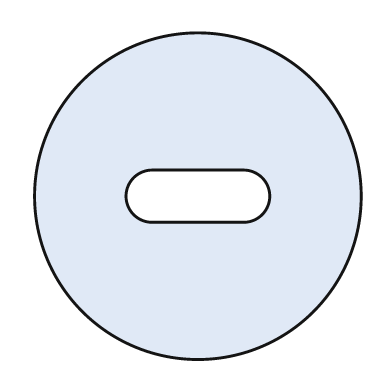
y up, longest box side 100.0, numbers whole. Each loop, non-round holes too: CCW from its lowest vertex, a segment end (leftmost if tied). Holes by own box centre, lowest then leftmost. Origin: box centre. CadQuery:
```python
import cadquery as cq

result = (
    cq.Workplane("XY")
    .moveTo(0.0, 0.0)
    .circle(50.0)
    .moveTo(-14.0, -8.0)
    .lineTo(14.0, -8.0)
    .threePointArc((22.0, 0.0), (14.0, 8.0))
    .lineTo(-14.0, 8.0)
    .threePointArc((-22.0, 0.0), (-14.0, -8.0))
    .close()
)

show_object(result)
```